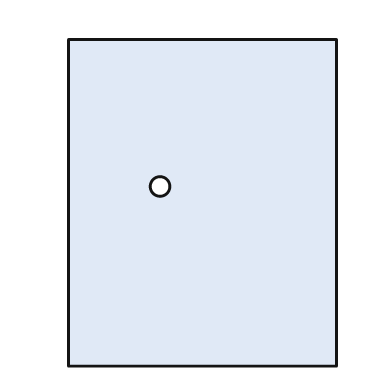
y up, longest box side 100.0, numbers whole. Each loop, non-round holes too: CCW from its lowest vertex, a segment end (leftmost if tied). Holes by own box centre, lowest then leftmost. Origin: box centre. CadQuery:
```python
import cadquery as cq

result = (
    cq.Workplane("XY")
    .moveTo(-41.0, -50.0)
    .lineTo(41.0, -50.0)
    .lineTo(41.0, 50.0)
    .lineTo(-41.0, 50.0)
    .close()
    .moveTo(-13.0, 5.0)
    .circle(3.0)
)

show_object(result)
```